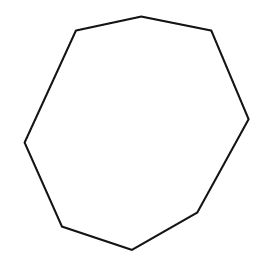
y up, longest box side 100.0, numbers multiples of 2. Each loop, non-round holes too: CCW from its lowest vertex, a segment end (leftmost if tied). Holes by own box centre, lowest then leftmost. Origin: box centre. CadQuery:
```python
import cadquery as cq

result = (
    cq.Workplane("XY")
    .moveTo(-2.0, -50.0)
    .lineTo(26.0, -34.0)
    .lineTo(48.0, 6.0)
    .lineTo(32.0, 44.0)
    .lineTo(2.0, 50.0)
    .lineTo(-26.0, 44.0)
    .lineTo(-48.0, -4.0)
    .lineTo(-32.0, -40.0)
    .close()
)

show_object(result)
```